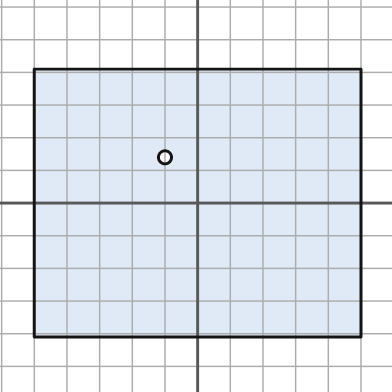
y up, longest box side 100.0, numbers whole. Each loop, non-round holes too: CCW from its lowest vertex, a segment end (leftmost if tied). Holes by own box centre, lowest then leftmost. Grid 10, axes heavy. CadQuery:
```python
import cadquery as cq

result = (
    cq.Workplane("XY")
    .moveTo(-50.0, -41.0)
    .lineTo(50.0, -41.0)
    .lineTo(50.0, 41.0)
    .lineTo(-50.0, 41.0)
    .close()
    .moveTo(-10.0, 14.0)
    .circle(2.0)
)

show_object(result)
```